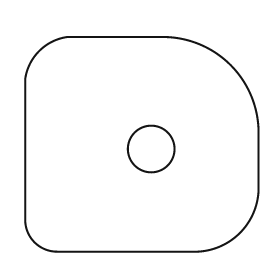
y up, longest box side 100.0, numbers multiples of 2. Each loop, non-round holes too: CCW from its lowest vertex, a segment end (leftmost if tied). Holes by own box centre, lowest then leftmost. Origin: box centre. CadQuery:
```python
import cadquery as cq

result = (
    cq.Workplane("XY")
    .moveTo(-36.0, -46.0)
    .lineTo(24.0, -46.0)
    .threePointArc((42.0, -38.0), (50.0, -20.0))
    .lineTo(50.0, 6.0)
    .threePointArc((38.0, 34.0), (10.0, 46.0))
    .lineTo(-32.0, 46.0)
    .threePointArc((-44.0, 40.0), (-50.0, 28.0))
    .lineTo(-50.0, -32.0)
    .threePointArc((-46.0, -42.0), (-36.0, -46.0))
    .close()
    .moveTo(4.0, -2.0)
    .circle(10.0)
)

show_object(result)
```